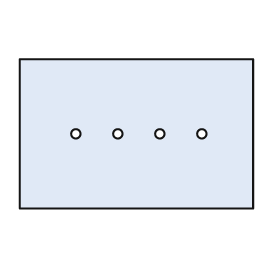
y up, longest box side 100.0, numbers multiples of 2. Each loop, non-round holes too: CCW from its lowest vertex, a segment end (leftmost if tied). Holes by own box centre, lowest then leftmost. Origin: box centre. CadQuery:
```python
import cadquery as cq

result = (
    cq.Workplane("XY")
    .moveTo(-50.0, -32.0)
    .lineTo(50.0, -32.0)
    .lineTo(50.0, 32.0)
    .lineTo(-50.0, 32.0)
    .close()
    .moveTo(-26.0, 0.0)
    .circle(2.0)
    .moveTo(-8.0, 0.0)
    .circle(2.0)
    .moveTo(10.0, 0.0)
    .circle(2.0)
    .moveTo(28.0, 0.0)
    .circle(2.0)
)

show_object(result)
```